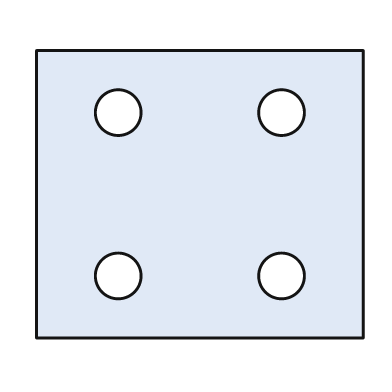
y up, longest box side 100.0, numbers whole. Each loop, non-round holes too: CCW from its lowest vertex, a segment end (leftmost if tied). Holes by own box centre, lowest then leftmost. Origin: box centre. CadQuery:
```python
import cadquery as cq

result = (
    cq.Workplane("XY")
    .moveTo(-50.0, -44.0)
    .lineTo(50.0, -44.0)
    .lineTo(50.0, 44.0)
    .lineTo(-50.0, 44.0)
    .close()
    .moveTo(-25.0, -25.0)
    .circle(7.0)
    .moveTo(25.0, -25.0)
    .circle(7.0)
    .moveTo(-25.0, 25.0)
    .circle(7.0)
    .moveTo(25.0, 25.0)
    .circle(7.0)
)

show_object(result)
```